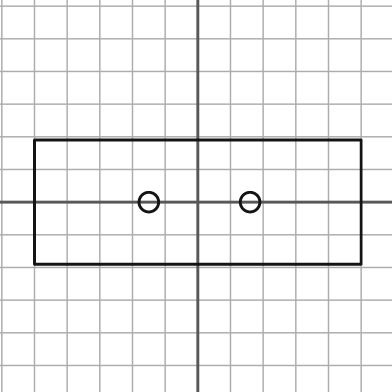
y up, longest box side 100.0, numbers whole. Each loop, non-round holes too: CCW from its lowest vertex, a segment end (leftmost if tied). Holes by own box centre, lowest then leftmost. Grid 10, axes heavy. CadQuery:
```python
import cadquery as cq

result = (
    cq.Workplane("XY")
    .moveTo(-50.0, -19.0)
    .lineTo(50.0, -19.0)
    .lineTo(50.0, 19.0)
    .lineTo(-50.0, 19.0)
    .close()
    .moveTo(-15.0, 0.0)
    .circle(3.0)
    .moveTo(16.0, 0.0)
    .circle(3.0)
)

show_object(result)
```